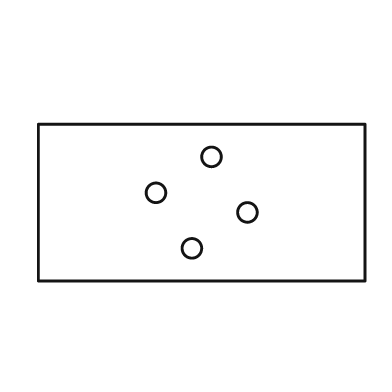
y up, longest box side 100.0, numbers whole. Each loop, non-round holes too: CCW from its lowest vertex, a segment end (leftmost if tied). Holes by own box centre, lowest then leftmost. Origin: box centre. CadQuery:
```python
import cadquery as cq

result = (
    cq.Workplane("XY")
    .moveTo(-50.0, -24.0)
    .lineTo(50.0, -24.0)
    .lineTo(50.0, 24.0)
    .lineTo(-50.0, 24.0)
    .close()
    .moveTo(-3.0, -14.0)
    .circle(3.0)
    .moveTo(14.0, -3.0)
    .circle(3.0)
    .moveTo(-14.0, 3.0)
    .circle(3.0)
    .moveTo(3.0, 14.0)
    .circle(3.0)
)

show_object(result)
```